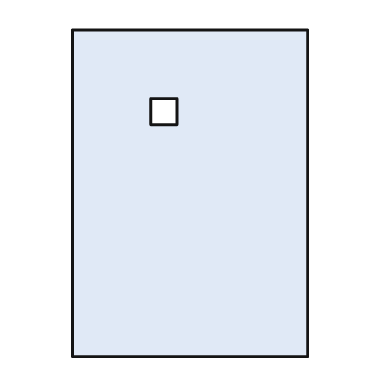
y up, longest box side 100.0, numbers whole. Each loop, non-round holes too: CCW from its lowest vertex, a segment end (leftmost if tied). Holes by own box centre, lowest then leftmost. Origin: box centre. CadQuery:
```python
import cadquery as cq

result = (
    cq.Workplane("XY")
    .moveTo(-36.0, -50.0)
    .lineTo(36.0, -50.0)
    .lineTo(36.0, 50.0)
    .lineTo(-36.0, 50.0)
    .close()
    .moveTo(-12.0, 21.0)
    .lineTo(-4.0, 21.0)
    .lineTo(-4.0, 29.0)
    .lineTo(-12.0, 29.0)
    .close()
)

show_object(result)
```